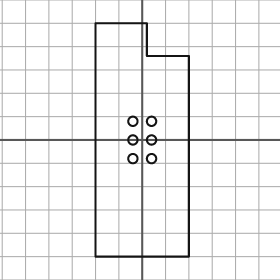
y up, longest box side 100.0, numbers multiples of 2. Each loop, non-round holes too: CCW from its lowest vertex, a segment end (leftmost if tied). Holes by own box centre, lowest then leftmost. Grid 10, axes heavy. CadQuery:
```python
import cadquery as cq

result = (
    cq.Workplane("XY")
    .moveTo(-20.0, -50.0)
    .lineTo(20.0, -50.0)
    .lineTo(20.0, 36.0)
    .lineTo(2.0, 36.0)
    .lineTo(2.0, 50.0)
    .lineTo(-20.0, 50.0)
    .close()
    .moveTo(-4.0, -8.0)
    .circle(2.0)
    .moveTo(4.0, -8.0)
    .circle(2.0)
    .moveTo(-4.0, 0.0)
    .circle(2.0)
    .moveTo(4.0, 0.0)
    .circle(2.0)
    .moveTo(-4.0, 8.0)
    .circle(2.0)
    .moveTo(4.0, 8.0)
    .circle(2.0)
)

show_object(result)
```